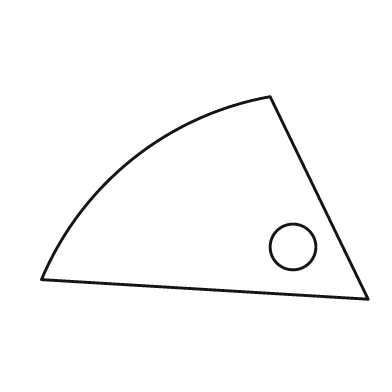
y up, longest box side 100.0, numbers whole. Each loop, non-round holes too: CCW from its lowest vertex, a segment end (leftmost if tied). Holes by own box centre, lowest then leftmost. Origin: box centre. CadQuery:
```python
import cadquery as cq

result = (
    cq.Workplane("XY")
    .moveTo(50.0, -31.0)
    .lineTo(20.0, 31.0)
    .threePointArc((-22.0, 12.0), (-50.0, -25.0))
    .close()
    .moveTo(27.0, -15.0)
    .circle(7.0)
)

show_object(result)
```